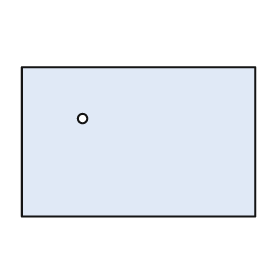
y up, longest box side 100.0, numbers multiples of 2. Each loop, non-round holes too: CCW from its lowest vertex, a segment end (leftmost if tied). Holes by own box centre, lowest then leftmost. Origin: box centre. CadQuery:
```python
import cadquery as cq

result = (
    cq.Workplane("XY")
    .moveTo(-50.0, -32.0)
    .lineTo(50.0, -32.0)
    .lineTo(50.0, 32.0)
    .lineTo(-50.0, 32.0)
    .close()
    .moveTo(-24.0, 10.0)
    .circle(2.0)
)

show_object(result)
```